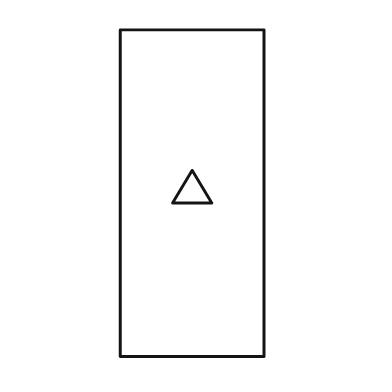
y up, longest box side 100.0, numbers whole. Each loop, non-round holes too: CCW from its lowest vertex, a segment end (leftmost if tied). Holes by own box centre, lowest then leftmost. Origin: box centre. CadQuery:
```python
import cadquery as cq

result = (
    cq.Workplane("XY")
    .moveTo(-22.0, -50.0)
    .lineTo(22.0, -50.0)
    .lineTo(22.0, 50.0)
    .lineTo(-22.0, 50.0)
    .close()
    .moveTo(-6.0, -3.0)
    .lineTo(6.0, -3.0)
    .lineTo(0.0, 7.0)
    .close()
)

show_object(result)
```